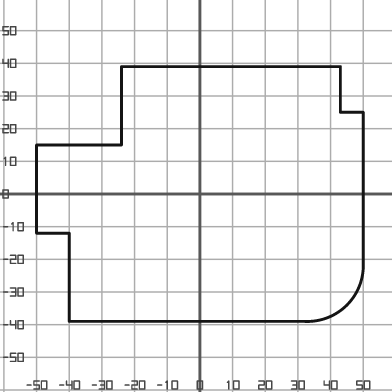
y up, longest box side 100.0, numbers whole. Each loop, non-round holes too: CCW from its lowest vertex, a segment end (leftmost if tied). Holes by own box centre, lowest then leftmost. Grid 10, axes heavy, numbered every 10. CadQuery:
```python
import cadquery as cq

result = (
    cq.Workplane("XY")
    .moveTo(-40.0, -39.0)
    .lineTo(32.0, -39.0)
    .threePointArc((45.0, -34.0), (50.0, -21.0))
    .lineTo(50.0, 25.0)
    .lineTo(43.0, 25.0)
    .lineTo(43.0, 39.0)
    .lineTo(-24.0, 39.0)
    .lineTo(-24.0, 15.0)
    .lineTo(-50.0, 15.0)
    .lineTo(-50.0, -12.0)
    .lineTo(-40.0, -12.0)
    .close()
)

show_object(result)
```